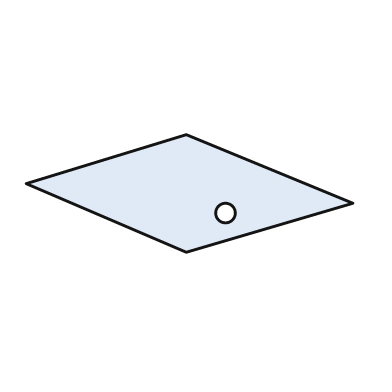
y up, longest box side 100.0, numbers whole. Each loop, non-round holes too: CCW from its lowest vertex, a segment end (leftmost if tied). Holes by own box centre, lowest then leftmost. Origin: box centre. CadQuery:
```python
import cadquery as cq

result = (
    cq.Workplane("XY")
    .moveTo(-1.0, -18.0)
    .lineTo(50.0, -3.0)
    .lineTo(-1.0, 18.0)
    .lineTo(-50.0, 3.0)
    .close()
    .moveTo(11.0, -6.0)
    .circle(3.0)
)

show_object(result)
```